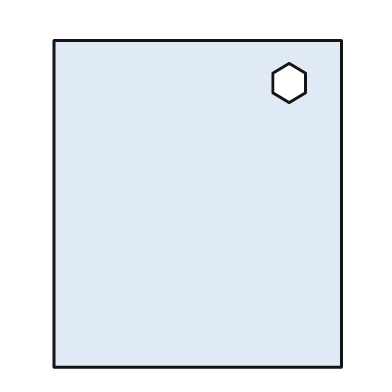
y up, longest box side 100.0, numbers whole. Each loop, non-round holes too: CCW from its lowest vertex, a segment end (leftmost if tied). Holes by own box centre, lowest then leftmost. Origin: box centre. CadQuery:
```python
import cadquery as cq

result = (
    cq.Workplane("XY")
    .moveTo(-44.0, -50.0)
    .lineTo(44.0, -50.0)
    .lineTo(44.0, 50.0)
    .lineTo(-44.0, 50.0)
    .close()
    .moveTo(28.0, 31.0)
    .lineTo(33.0, 34.0)
    .lineTo(33.0, 40.0)
    .lineTo(28.0, 43.0)
    .lineTo(23.0, 40.0)
    .lineTo(23.0, 34.0)
    .close()
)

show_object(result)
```